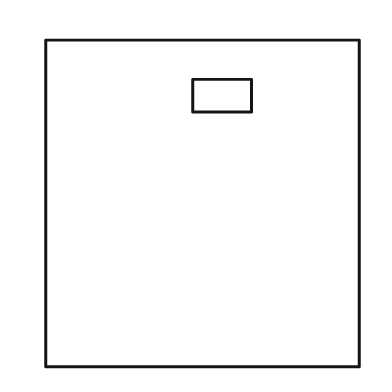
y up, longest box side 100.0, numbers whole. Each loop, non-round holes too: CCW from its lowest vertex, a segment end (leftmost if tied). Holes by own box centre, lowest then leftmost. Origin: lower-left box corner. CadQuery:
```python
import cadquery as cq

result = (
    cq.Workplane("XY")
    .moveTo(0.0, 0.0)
    .lineTo(96.0, 0.0)
    .lineTo(96.0, 100.0)
    .lineTo(0.0, 100.0)
    .close()
    .moveTo(45.0, 78.0)
    .lineTo(63.0, 78.0)
    .lineTo(63.0, 88.0)
    .lineTo(45.0, 88.0)
    .close()
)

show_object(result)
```